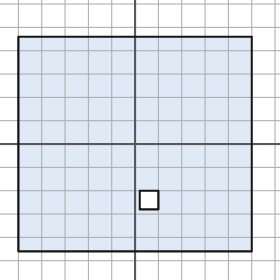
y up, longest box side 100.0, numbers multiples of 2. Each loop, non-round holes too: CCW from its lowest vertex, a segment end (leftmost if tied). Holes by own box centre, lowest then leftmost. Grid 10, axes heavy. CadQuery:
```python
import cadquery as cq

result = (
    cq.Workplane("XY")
    .moveTo(-50.0, -46.0)
    .lineTo(50.0, -46.0)
    .lineTo(50.0, 46.0)
    .lineTo(-50.0, 46.0)
    .close()
    .moveTo(2.0, -28.0)
    .lineTo(10.0, -28.0)
    .lineTo(10.0, -20.0)
    .lineTo(2.0, -20.0)
    .close()
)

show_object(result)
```